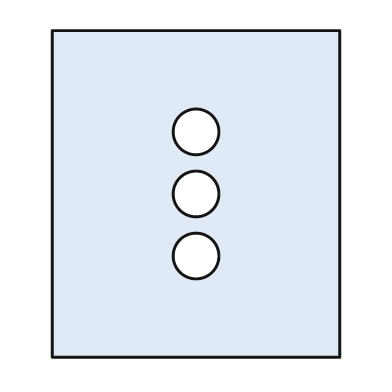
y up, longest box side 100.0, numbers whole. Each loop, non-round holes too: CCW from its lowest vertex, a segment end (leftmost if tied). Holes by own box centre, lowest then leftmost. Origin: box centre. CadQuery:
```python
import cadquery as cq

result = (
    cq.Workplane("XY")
    .moveTo(-44.0, -50.0)
    .lineTo(44.0, -50.0)
    .lineTo(44.0, 50.0)
    .lineTo(-44.0, 50.0)
    .close()
    .moveTo(0.0, -19.0)
    .circle(7.0)
    .moveTo(0.0, 0.0)
    .circle(7.0)
    .moveTo(0.0, 19.0)
    .circle(7.0)
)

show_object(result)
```